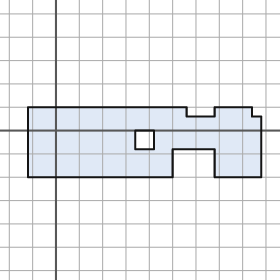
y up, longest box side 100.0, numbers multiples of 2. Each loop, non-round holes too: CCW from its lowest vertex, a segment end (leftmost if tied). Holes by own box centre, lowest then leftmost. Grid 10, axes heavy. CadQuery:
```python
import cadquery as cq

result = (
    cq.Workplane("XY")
    .moveTo(-12.0, -20.0)
    .lineTo(50.0, -20.0)
    .lineTo(50.0, -8.0)
    .lineTo(68.0, -8.0)
    .lineTo(68.0, -20.0)
    .lineTo(88.0, -20.0)
    .lineTo(88.0, 6.0)
    .lineTo(84.0, 6.0)
    .lineTo(84.0, 10.0)
    .lineTo(68.0, 10.0)
    .lineTo(68.0, 6.0)
    .lineTo(56.0, 6.0)
    .lineTo(56.0, 10.0)
    .lineTo(-12.0, 10.0)
    .close()
    .moveTo(34.0, -8.0)
    .lineTo(42.0, -8.0)
    .lineTo(42.0, 0.0)
    .lineTo(34.0, 0.0)
    .close()
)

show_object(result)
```